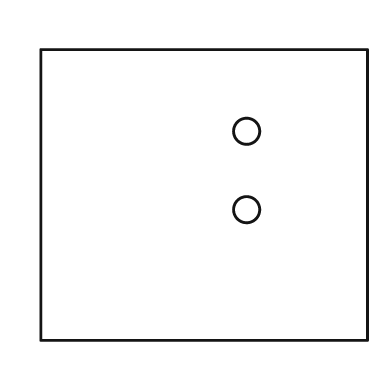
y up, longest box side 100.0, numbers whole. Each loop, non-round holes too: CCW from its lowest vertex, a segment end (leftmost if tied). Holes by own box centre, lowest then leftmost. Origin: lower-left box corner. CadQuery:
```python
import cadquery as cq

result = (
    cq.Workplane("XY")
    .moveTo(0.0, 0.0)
    .lineTo(100.0, 0.0)
    .lineTo(100.0, 89.0)
    .lineTo(0.0, 89.0)
    .close()
    .moveTo(63.0, 40.0)
    .circle(4.0)
    .moveTo(63.0, 64.0)
    .circle(4.0)
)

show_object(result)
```